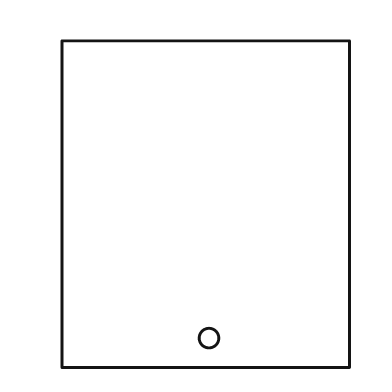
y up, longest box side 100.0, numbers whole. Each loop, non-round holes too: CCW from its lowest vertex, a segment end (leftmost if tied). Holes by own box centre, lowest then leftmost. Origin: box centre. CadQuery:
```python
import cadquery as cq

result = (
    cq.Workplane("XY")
    .moveTo(-44.0, -50.0)
    .lineTo(44.0, -50.0)
    .lineTo(44.0, 50.0)
    .lineTo(-44.0, 50.0)
    .close()
    .moveTo(1.0, -41.0)
    .circle(3.0)
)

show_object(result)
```